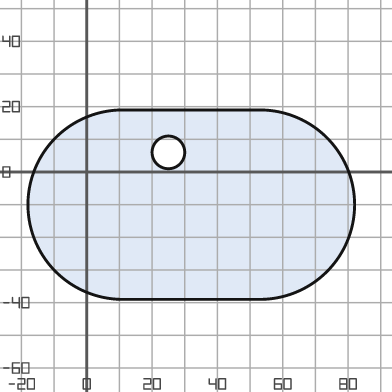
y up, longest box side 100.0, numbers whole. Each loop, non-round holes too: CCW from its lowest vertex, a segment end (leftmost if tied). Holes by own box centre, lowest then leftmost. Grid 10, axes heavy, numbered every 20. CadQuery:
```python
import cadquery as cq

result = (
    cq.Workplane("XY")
    .moveTo(11.0, -39.0)
    .lineTo(53.0, -39.0)
    .threePointArc((82.0, -10.0), (53.0, 19.0))
    .lineTo(11.0, 19.0)
    .threePointArc((-18.0, -10.0), (11.0, -39.0))
    .close()
    .moveTo(25.0, 6.0)
    .circle(5.0)
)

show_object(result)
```